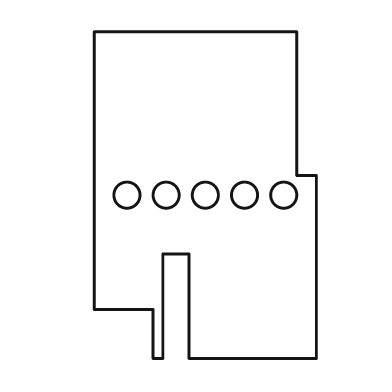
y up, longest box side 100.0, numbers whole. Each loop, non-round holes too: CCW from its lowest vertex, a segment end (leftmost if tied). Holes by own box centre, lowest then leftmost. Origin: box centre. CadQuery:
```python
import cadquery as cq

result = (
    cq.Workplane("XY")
    .moveTo(-16.0, -50.0)
    .lineTo(-13.0, -50.0)
    .lineTo(-13.0, -18.0)
    .lineTo(-5.0, -18.0)
    .lineTo(-5.0, -50.0)
    .lineTo(34.0, -50.0)
    .lineTo(34.0, 6.0)
    .lineTo(28.0, 6.0)
    .lineTo(28.0, 50.0)
    .lineTo(-34.0, 50.0)
    .lineTo(-34.0, -35.0)
    .lineTo(-16.0, -35.0)
    .close()
    .moveTo(-24.0, 0.0)
    .circle(4.0)
    .moveTo(-12.0, 0.0)
    .circle(4.0)
    .moveTo(0.0, 0.0)
    .circle(4.0)
    .moveTo(12.0, 0.0)
    .circle(4.0)
    .moveTo(24.0, 0.0)
    .circle(4.0)
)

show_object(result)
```